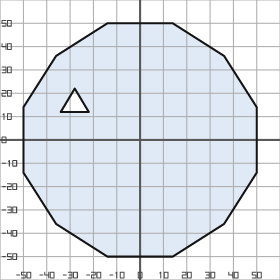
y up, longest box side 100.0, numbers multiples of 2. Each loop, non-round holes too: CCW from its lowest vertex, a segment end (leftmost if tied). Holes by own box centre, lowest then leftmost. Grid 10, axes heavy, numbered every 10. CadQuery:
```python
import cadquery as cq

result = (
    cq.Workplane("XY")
    .moveTo(-14.0, -50.0)
    .lineTo(14.0, -50.0)
    .lineTo(36.0, -36.0)
    .lineTo(50.0, -14.0)
    .lineTo(50.0, 14.0)
    .lineTo(36.0, 36.0)
    .lineTo(14.0, 50.0)
    .lineTo(-14.0, 50.0)
    .lineTo(-36.0, 36.0)
    .lineTo(-50.0, 14.0)
    .lineTo(-50.0, -14.0)
    .lineTo(-36.0, -36.0)
    .close()
    .moveTo(-34.0, 12.0)
    .lineTo(-22.0, 12.0)
    .lineTo(-28.0, 22.0)
    .close()
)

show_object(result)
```